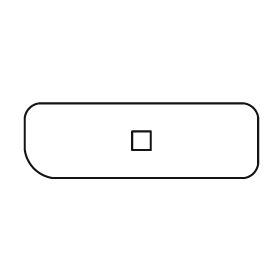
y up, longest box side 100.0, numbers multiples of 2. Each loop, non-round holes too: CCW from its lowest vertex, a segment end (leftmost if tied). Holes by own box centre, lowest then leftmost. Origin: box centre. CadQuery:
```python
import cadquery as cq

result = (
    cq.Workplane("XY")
    .moveTo(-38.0, -16.0)
    .lineTo(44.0, -16.0)
    .threePointArc((48.0, -14.0), (50.0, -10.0))
    .lineTo(50.0, 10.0)
    .threePointArc((48.0, 14.0), (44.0, 16.0))
    .lineTo(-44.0, 16.0)
    .threePointArc((-48.0, 14.0), (-50.0, 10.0))
    .lineTo(-50.0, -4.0)
    .threePointArc((-46.0, -12.0), (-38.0, -16.0))
    .close()
    .moveTo(-4.0, -4.0)
    .lineTo(4.0, -4.0)
    .lineTo(4.0, 4.0)
    .lineTo(-4.0, 4.0)
    .close()
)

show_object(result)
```